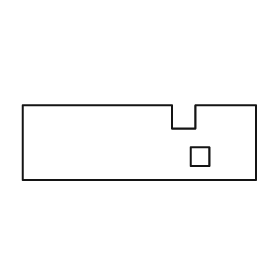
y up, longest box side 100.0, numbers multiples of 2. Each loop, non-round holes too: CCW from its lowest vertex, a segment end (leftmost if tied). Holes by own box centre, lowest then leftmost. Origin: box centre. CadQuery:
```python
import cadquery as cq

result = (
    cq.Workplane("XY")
    .moveTo(-50.0, -16.0)
    .lineTo(50.0, -16.0)
    .lineTo(50.0, 16.0)
    .lineTo(24.0, 16.0)
    .lineTo(24.0, 6.0)
    .lineTo(14.0, 6.0)
    .lineTo(14.0, 16.0)
    .lineTo(-50.0, 16.0)
    .close()
    .moveTo(22.0, -10.0)
    .lineTo(30.0, -10.0)
    .lineTo(30.0, -2.0)
    .lineTo(22.0, -2.0)
    .close()
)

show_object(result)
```